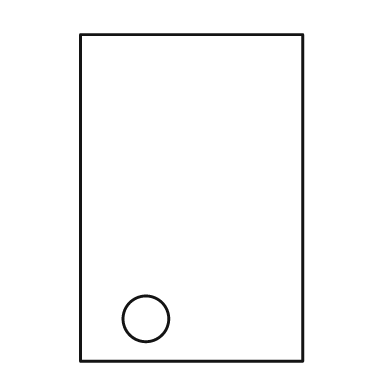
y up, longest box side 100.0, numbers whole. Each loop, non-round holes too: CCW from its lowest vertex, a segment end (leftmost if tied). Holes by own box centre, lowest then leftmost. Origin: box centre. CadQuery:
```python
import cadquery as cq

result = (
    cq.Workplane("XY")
    .moveTo(-34.0, -50.0)
    .lineTo(34.0, -50.0)
    .lineTo(34.0, 50.0)
    .lineTo(-34.0, 50.0)
    .close()
    .moveTo(-14.0, -37.0)
    .circle(7.0)
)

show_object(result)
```